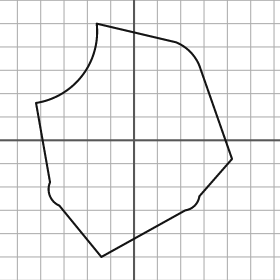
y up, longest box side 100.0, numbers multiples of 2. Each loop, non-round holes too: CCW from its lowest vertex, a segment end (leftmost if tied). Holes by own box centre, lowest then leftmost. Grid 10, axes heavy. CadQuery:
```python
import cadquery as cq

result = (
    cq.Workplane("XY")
    .moveTo(-14.0, -50.0)
    .lineTo(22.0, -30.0)
    .threePointArc((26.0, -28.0), (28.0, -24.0))
    .lineTo(42.0, -8.0)
    .lineTo(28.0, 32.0)
    .threePointArc((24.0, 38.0), (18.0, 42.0))
    .lineTo(-16.0, 50.0)
    .threePointArc((-22.0, 28.0), (-42.0, 16.0))
    .lineTo(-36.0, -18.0)
    .threePointArc((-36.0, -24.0), (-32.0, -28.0))
    .close()
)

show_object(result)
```